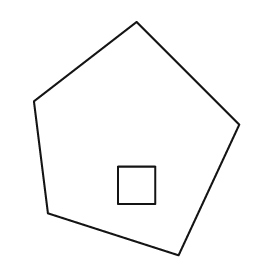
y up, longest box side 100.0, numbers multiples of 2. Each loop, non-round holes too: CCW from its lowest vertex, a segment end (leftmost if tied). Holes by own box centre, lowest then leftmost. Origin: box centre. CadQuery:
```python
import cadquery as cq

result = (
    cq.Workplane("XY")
    .moveTo(18.0, -50.0)
    .lineTo(44.0, 6.0)
    .lineTo(0.0, 50.0)
    .lineTo(-44.0, 16.0)
    .lineTo(-38.0, -32.0)
    .close()
    .moveTo(-8.0, -28.0)
    .lineTo(8.0, -28.0)
    .lineTo(8.0, -12.0)
    .lineTo(-8.0, -12.0)
    .close()
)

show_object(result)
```